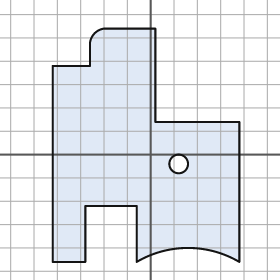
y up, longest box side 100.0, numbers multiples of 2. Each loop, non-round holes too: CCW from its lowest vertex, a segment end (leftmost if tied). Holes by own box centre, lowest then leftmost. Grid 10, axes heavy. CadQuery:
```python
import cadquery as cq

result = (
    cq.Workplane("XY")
    .moveTo(-42.0, -46.0)
    .lineTo(-28.0, -46.0)
    .lineTo(-28.0, -22.0)
    .lineTo(-6.0, -22.0)
    .lineTo(-6.0, -46.0)
    .threePointArc((16.0, -40.0), (38.0, -46.0))
    .lineTo(38.0, 14.0)
    .lineTo(2.0, 14.0)
    .lineTo(2.0, 54.0)
    .lineTo(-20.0, 54.0)
    .threePointArc((-24.0, 52.0), (-26.0, 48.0))
    .lineTo(-26.0, 38.0)
    .lineTo(-42.0, 38.0)
    .close()
    .moveTo(12.0, -4.0)
    .circle(4.0)
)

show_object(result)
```